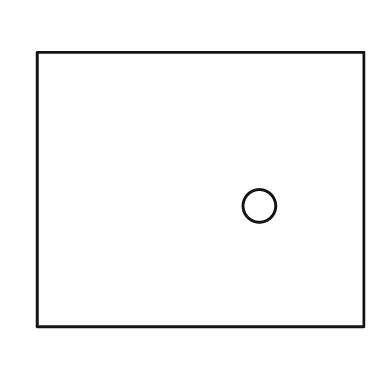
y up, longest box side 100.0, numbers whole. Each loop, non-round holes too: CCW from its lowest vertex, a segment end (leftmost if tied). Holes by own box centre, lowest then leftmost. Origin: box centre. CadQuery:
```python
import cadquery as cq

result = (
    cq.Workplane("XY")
    .moveTo(-50.0, -42.0)
    .lineTo(50.0, -42.0)
    .lineTo(50.0, 42.0)
    .lineTo(-50.0, 42.0)
    .close()
    .moveTo(18.0, -5.0)
    .circle(5.0)
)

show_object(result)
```